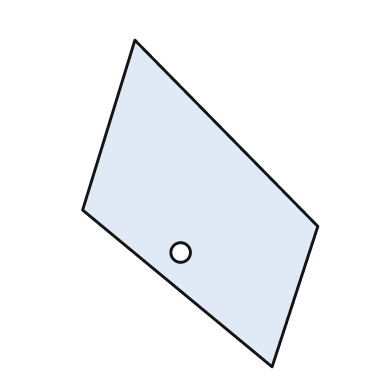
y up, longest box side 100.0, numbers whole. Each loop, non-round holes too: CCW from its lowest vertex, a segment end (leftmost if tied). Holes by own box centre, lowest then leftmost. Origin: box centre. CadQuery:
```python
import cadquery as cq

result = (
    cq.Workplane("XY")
    .moveTo(22.0, -50.0)
    .lineTo(36.0, -7.0)
    .lineTo(-20.0, 50.0)
    .lineTo(-36.0, -2.0)
    .close()
    .moveTo(-6.0, -15.0)
    .circle(3.0)
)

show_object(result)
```